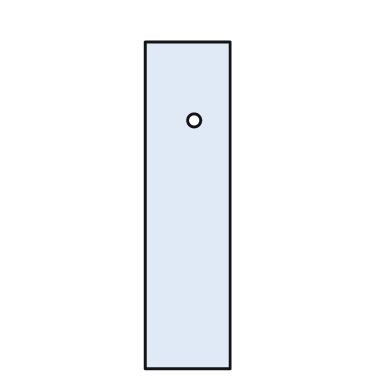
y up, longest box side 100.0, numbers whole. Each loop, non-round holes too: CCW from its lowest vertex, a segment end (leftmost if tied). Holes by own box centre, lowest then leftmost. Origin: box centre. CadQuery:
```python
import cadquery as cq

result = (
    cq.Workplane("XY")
    .moveTo(-13.0, -50.0)
    .lineTo(13.0, -50.0)
    .lineTo(13.0, 50.0)
    .lineTo(-13.0, 50.0)
    .close()
    .moveTo(2.0, 26.0)
    .circle(2.0)
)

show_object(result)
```